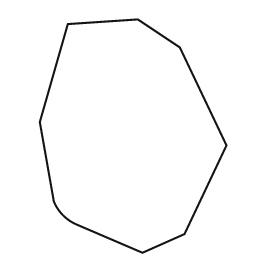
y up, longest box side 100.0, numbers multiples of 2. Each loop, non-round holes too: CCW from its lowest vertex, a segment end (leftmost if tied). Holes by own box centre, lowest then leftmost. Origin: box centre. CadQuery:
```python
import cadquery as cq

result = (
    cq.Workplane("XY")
    .moveTo(4.0, -50.0)
    .lineTo(22.0, -42.0)
    .lineTo(40.0, -4.0)
    .lineTo(20.0, 38.0)
    .lineTo(2.0, 50.0)
    .lineTo(-28.0, 48.0)
    .lineTo(-40.0, 6.0)
    .lineTo(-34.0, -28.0)
    .threePointArc((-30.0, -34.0), (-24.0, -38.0))
    .close()
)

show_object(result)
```